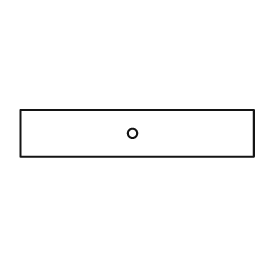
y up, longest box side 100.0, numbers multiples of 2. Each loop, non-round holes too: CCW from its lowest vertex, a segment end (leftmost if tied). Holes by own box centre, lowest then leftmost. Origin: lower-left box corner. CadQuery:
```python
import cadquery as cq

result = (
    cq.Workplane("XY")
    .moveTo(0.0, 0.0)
    .lineTo(100.0, 0.0)
    .lineTo(100.0, 20.0)
    .lineTo(0.0, 20.0)
    .close()
    .moveTo(48.0, 10.0)
    .circle(2.0)
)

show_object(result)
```